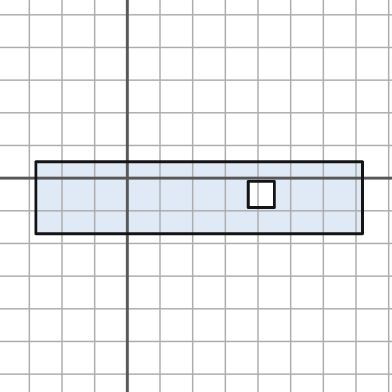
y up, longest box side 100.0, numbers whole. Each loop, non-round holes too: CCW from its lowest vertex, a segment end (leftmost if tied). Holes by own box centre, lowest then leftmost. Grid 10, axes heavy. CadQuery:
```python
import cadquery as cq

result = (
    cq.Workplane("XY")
    .moveTo(-28.0, -17.0)
    .lineTo(72.0, -17.0)
    .lineTo(72.0, 5.0)
    .lineTo(-28.0, 5.0)
    .close()
    .moveTo(37.0, -9.0)
    .lineTo(45.0, -9.0)
    .lineTo(45.0, -1.0)
    .lineTo(37.0, -1.0)
    .close()
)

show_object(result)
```